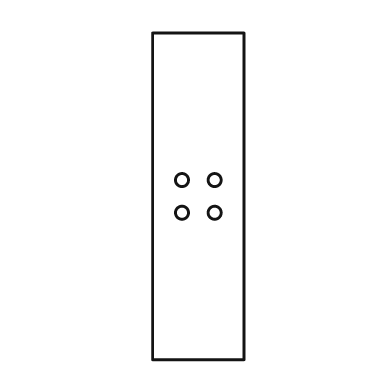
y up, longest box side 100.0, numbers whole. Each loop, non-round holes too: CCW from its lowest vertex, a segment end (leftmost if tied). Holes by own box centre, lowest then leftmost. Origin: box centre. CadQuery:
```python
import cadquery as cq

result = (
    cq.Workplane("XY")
    .moveTo(-14.0, -50.0)
    .lineTo(14.0, -50.0)
    .lineTo(14.0, 50.0)
    .lineTo(-14.0, 50.0)
    .close()
    .moveTo(-5.0, -5.0)
    .circle(2.0)
    .moveTo(5.0, -5.0)
    .circle(2.0)
    .moveTo(-5.0, 5.0)
    .circle(2.0)
    .moveTo(5.0, 5.0)
    .circle(2.0)
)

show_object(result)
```